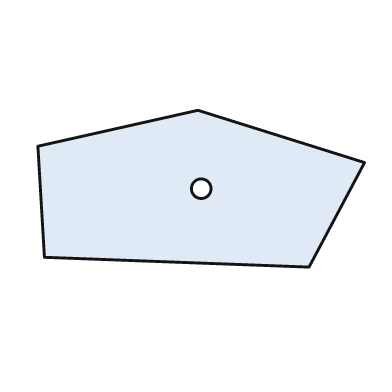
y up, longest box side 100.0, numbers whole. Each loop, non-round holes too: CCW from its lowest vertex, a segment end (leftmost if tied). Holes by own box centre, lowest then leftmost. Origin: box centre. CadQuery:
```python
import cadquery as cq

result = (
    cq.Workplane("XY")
    .moveTo(33.0, -24.0)
    .lineTo(50.0, 8.0)
    .lineTo(-1.0, 24.0)
    .lineTo(-50.0, 13.0)
    .lineTo(-48.0, -21.0)
    .close()
    .moveTo(0.0, 0.0)
    .circle(3.0)
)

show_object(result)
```